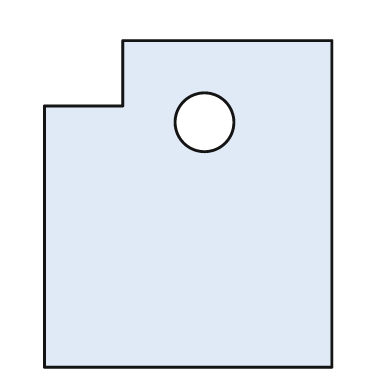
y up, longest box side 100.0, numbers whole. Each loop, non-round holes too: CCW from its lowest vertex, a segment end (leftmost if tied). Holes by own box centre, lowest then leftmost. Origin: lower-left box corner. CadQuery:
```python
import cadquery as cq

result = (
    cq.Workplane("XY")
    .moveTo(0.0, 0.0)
    .lineTo(88.0, 0.0)
    .lineTo(88.0, 100.0)
    .lineTo(24.0, 100.0)
    .lineTo(24.0, 80.0)
    .lineTo(0.0, 80.0)
    .close()
    .moveTo(49.0, 75.0)
    .circle(9.0)
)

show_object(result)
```